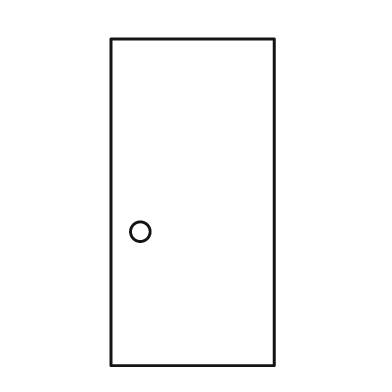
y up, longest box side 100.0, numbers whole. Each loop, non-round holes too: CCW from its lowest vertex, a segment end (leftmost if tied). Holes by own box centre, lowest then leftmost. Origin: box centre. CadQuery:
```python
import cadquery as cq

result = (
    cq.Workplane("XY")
    .moveTo(-25.0, -50.0)
    .lineTo(25.0, -50.0)
    .lineTo(25.0, 50.0)
    .lineTo(-25.0, 50.0)
    .close()
    .moveTo(-16.0, -9.0)
    .circle(3.0)
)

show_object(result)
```